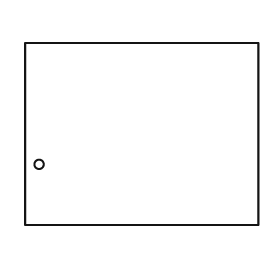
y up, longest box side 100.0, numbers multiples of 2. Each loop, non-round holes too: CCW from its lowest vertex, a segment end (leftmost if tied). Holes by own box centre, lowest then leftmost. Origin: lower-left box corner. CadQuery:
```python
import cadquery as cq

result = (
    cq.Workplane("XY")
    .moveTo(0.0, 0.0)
    .lineTo(100.0, 0.0)
    .lineTo(100.0, 78.0)
    .lineTo(0.0, 78.0)
    .close()
    .moveTo(6.0, 26.0)
    .circle(2.0)
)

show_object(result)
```